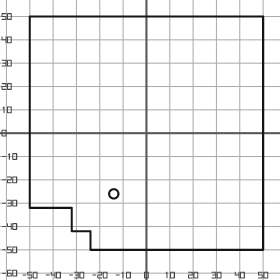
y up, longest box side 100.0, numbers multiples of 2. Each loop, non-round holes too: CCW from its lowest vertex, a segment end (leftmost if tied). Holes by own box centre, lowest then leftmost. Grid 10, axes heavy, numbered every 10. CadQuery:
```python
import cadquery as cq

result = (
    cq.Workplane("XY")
    .moveTo(-24.0, -50.0)
    .lineTo(50.0, -50.0)
    .lineTo(50.0, 50.0)
    .lineTo(-50.0, 50.0)
    .lineTo(-50.0, -32.0)
    .lineTo(-32.0, -32.0)
    .lineTo(-32.0, -42.0)
    .lineTo(-24.0, -42.0)
    .close()
    .moveTo(-14.0, -26.0)
    .circle(2.0)
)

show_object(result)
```